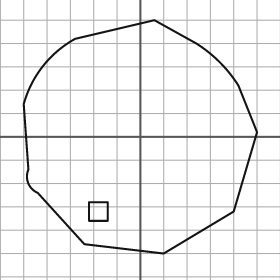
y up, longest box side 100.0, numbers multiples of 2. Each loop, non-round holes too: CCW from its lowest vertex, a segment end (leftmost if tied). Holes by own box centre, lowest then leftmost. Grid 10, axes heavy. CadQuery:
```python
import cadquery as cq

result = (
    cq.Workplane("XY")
    .moveTo(10.0, -50.0)
    .lineTo(40.0, -32.0)
    .lineTo(50.0, 2.0)
    .lineTo(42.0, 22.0)
    .threePointArc((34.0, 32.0), (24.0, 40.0))
    .lineTo(6.0, 50.0)
    .lineTo(-28.0, 42.0)
    .threePointArc((-42.0, 30.0), (-50.0, 14.0))
    .lineTo(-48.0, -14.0)
    .threePointArc((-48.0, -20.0), (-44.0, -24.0))
    .lineTo(-24.0, -46.0)
    .close()
    .moveTo(-22.0, -36.0)
    .lineTo(-14.0, -36.0)
    .lineTo(-14.0, -28.0)
    .lineTo(-22.0, -28.0)
    .close()
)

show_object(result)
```